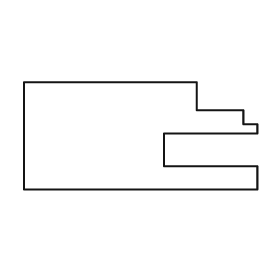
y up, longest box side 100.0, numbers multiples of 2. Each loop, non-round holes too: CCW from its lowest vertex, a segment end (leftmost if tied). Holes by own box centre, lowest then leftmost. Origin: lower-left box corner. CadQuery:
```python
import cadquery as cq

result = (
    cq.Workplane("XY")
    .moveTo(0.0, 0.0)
    .lineTo(100.0, 0.0)
    .lineTo(100.0, 10.0)
    .lineTo(60.0, 10.0)
    .lineTo(60.0, 24.0)
    .lineTo(100.0, 24.0)
    .lineTo(100.0, 28.0)
    .lineTo(94.0, 28.0)
    .lineTo(94.0, 34.0)
    .lineTo(74.0, 34.0)
    .lineTo(74.0, 46.0)
    .lineTo(0.0, 46.0)
    .close()
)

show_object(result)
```